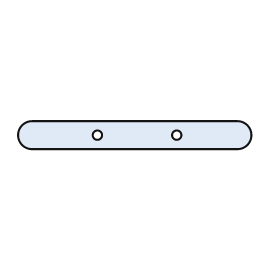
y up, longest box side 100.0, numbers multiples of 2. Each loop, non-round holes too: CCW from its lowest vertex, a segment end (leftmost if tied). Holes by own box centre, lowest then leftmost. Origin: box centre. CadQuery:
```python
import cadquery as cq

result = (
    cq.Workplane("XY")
    .moveTo(-44.0, -6.0)
    .lineTo(44.0, -6.0)
    .threePointArc((50.0, 0.0), (44.0, 6.0))
    .lineTo(-44.0, 6.0)
    .threePointArc((-50.0, 0.0), (-44.0, -6.0))
    .close()
    .moveTo(-16.0, 0.0)
    .circle(2.0)
    .moveTo(18.0, 0.0)
    .circle(2.0)
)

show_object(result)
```